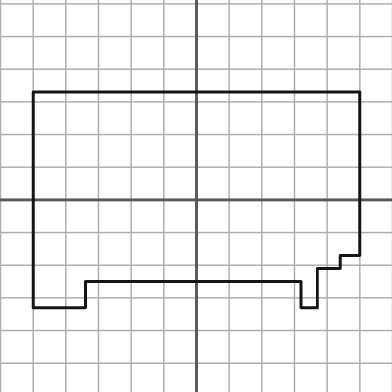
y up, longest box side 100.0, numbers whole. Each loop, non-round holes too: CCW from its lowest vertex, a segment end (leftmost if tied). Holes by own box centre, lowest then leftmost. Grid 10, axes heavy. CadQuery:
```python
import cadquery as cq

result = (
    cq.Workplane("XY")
    .moveTo(-50.0, -33.0)
    .lineTo(-34.0, -33.0)
    .lineTo(-34.0, -25.0)
    .lineTo(32.0, -25.0)
    .lineTo(32.0, -33.0)
    .lineTo(37.0, -33.0)
    .lineTo(37.0, -21.0)
    .lineTo(44.0, -21.0)
    .lineTo(44.0, -17.0)
    .lineTo(50.0, -17.0)
    .lineTo(50.0, 33.0)
    .lineTo(-50.0, 33.0)
    .close()
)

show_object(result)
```